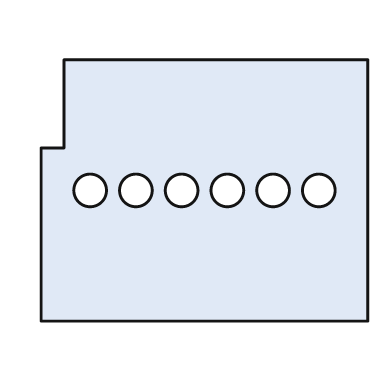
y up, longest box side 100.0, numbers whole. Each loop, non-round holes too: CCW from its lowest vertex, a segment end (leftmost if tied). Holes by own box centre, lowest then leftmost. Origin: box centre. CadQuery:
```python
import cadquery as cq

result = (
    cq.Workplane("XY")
    .moveTo(-50.0, -40.0)
    .lineTo(50.0, -40.0)
    .lineTo(50.0, 40.0)
    .lineTo(-43.0, 40.0)
    .lineTo(-43.0, 13.0)
    .lineTo(-50.0, 13.0)
    .close()
    .moveTo(-35.0, 0.0)
    .circle(5.0)
    .moveTo(-21.0, 0.0)
    .circle(5.0)
    .moveTo(-7.0, 0.0)
    .circle(5.0)
    .moveTo(7.0, 0.0)
    .circle(5.0)
    .moveTo(21.0, 0.0)
    .circle(5.0)
    .moveTo(35.0, 0.0)
    .circle(5.0)
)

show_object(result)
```